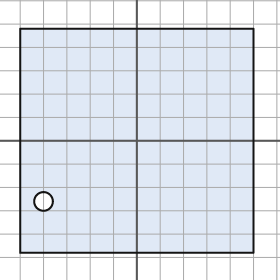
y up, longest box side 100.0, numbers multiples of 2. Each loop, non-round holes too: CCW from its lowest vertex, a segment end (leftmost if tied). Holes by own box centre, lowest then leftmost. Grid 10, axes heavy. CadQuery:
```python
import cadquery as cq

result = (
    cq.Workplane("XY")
    .moveTo(-50.0, -48.0)
    .lineTo(50.0, -48.0)
    .lineTo(50.0, 48.0)
    .lineTo(-50.0, 48.0)
    .close()
    .moveTo(-40.0, -26.0)
    .circle(4.0)
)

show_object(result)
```